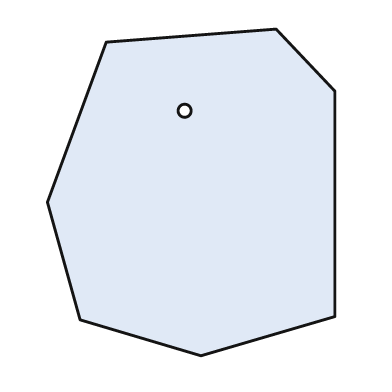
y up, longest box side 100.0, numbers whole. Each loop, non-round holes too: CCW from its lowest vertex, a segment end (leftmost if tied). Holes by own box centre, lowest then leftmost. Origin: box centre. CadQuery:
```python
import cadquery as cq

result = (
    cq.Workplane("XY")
    .moveTo(3.0, -50.0)
    .lineTo(44.0, -38.0)
    .lineTo(44.0, 31.0)
    .lineTo(26.0, 50.0)
    .lineTo(-26.0, 46.0)
    .lineTo(-44.0, -3.0)
    .lineTo(-34.0, -39.0)
    .close()
    .moveTo(-2.0, 25.0)
    .circle(2.0)
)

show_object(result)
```